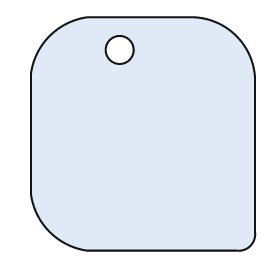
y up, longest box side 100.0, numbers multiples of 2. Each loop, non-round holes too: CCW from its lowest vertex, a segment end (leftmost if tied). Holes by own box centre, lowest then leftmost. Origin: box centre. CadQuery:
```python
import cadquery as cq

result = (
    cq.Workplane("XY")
    .moveTo(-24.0, -50.0)
    .lineTo(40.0, -50.0)
    .threePointArc((46.0, -48.0), (48.0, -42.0))
    .lineTo(48.0, 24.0)
    .threePointArc((40.0, 42.0), (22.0, 50.0))
    .lineTo(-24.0, 50.0)
    .threePointArc((-40.0, 42.0), (-48.0, 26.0))
    .lineTo(-48.0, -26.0)
    .threePointArc((-40.0, -42.0), (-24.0, -50.0))
    .close()
    .moveTo(-10.0, 36.0)
    .circle(6.0)
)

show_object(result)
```